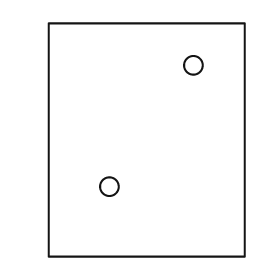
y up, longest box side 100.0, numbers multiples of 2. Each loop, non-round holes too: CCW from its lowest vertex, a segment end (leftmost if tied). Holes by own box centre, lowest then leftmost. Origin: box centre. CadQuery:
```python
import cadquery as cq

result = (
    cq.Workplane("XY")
    .moveTo(-42.0, -50.0)
    .lineTo(42.0, -50.0)
    .lineTo(42.0, 50.0)
    .lineTo(-42.0, 50.0)
    .close()
    .moveTo(-16.0, -20.0)
    .circle(4.0)
    .moveTo(20.0, 32.0)
    .circle(4.0)
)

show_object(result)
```